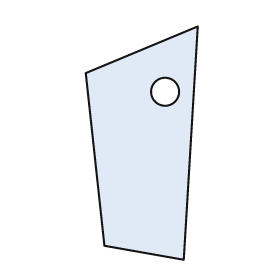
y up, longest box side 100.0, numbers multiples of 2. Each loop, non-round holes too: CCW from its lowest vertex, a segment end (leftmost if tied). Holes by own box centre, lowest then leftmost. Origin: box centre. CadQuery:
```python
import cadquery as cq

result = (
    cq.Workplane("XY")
    .moveTo(18.0, -50.0)
    .lineTo(24.0, 50.0)
    .lineTo(-24.0, 30.0)
    .lineTo(-16.0, -44.0)
    .close()
    .moveTo(10.0, 22.0)
    .circle(6.0)
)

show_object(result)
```